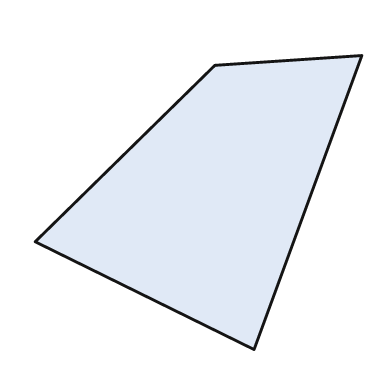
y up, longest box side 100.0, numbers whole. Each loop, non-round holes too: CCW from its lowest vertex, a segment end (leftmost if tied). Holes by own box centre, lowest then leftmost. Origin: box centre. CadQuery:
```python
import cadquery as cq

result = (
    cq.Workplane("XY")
    .moveTo(17.0, -45.0)
    .lineTo(50.0, 45.0)
    .lineTo(5.0, 42.0)
    .lineTo(-50.0, -12.0)
    .close()
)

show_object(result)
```